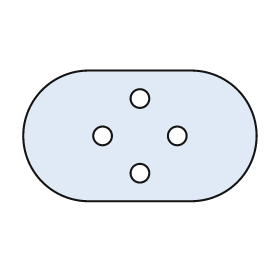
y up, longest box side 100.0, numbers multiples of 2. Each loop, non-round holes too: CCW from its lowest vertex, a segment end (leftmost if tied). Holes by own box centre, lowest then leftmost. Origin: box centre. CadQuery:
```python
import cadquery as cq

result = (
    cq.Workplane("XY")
    .moveTo(-22.0, -28.0)
    .lineTo(22.0, -28.0)
    .threePointArc((50.0, 0.0), (22.0, 28.0))
    .lineTo(-22.0, 28.0)
    .threePointArc((-50.0, 0.0), (-22.0, -28.0))
    .close()
    .moveTo(0.0, -16.0)
    .circle(4.0)
    .moveTo(-16.0, 0.0)
    .circle(4.0)
    .moveTo(16.0, 0.0)
    .circle(4.0)
    .moveTo(0.0, 16.0)
    .circle(4.0)
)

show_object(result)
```